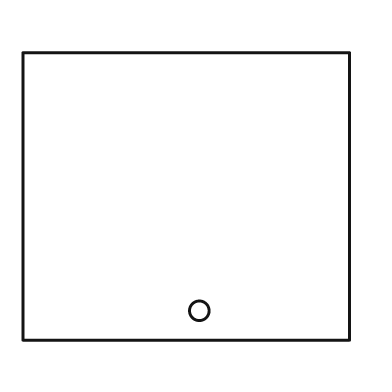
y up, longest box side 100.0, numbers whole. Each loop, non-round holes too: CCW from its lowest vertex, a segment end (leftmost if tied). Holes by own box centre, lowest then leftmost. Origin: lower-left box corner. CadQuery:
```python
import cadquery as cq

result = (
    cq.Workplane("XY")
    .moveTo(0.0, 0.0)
    .lineTo(100.0, 0.0)
    .lineTo(100.0, 88.0)
    .lineTo(0.0, 88.0)
    .close()
    .moveTo(54.0, 9.0)
    .circle(3.0)
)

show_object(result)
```